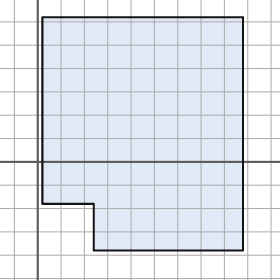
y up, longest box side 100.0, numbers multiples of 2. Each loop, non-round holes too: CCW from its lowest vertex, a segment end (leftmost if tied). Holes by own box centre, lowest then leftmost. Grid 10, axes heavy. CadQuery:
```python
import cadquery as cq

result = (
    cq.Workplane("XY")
    .moveTo(24.0, -38.0)
    .lineTo(88.0, -38.0)
    .lineTo(88.0, 62.0)
    .lineTo(2.0, 62.0)
    .lineTo(2.0, -18.0)
    .lineTo(24.0, -18.0)
    .close()
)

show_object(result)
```